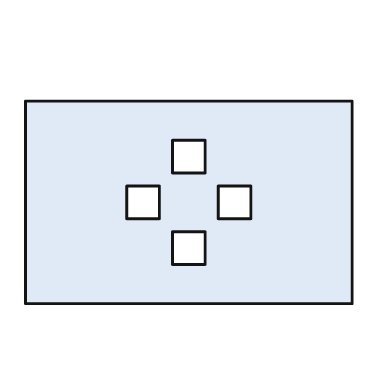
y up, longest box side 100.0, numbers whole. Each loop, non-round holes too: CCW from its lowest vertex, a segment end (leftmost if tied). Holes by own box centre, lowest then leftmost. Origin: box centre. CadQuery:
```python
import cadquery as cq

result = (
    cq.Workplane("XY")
    .moveTo(-50.0, -31.0)
    .lineTo(50.0, -31.0)
    .lineTo(50.0, 31.0)
    .lineTo(-50.0, 31.0)
    .close()
    .moveTo(-5.0, -19.0)
    .lineTo(5.0, -19.0)
    .lineTo(5.0, -9.0)
    .lineTo(-5.0, -9.0)
    .close()
    .moveTo(-19.0, -5.0)
    .lineTo(-9.0, -5.0)
    .lineTo(-9.0, 5.0)
    .lineTo(-19.0, 5.0)
    .close()
    .moveTo(9.0, -5.0)
    .lineTo(19.0, -5.0)
    .lineTo(19.0, 5.0)
    .lineTo(9.0, 5.0)
    .close()
    .moveTo(-5.0, 9.0)
    .lineTo(5.0, 9.0)
    .lineTo(5.0, 19.0)
    .lineTo(-5.0, 19.0)
    .close()
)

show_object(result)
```